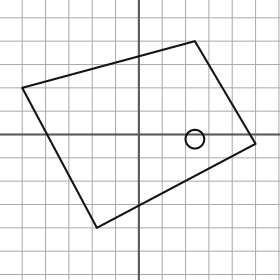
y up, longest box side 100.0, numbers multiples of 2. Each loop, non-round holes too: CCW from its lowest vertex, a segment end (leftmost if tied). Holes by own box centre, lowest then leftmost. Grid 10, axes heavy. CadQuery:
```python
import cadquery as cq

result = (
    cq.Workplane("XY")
    .moveTo(-18.0, -40.0)
    .lineTo(50.0, -4.0)
    .lineTo(24.0, 40.0)
    .lineTo(-50.0, 20.0)
    .close()
    .moveTo(24.0, -2.0)
    .circle(4.0)
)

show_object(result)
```